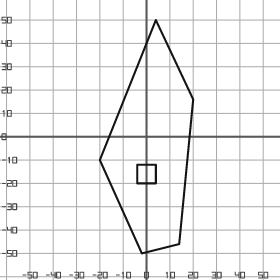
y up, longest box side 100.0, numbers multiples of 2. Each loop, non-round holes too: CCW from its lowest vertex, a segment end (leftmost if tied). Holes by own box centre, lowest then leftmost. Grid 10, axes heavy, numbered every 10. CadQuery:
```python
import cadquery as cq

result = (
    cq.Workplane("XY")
    .moveTo(-2.0, -50.0)
    .lineTo(14.0, -46.0)
    .lineTo(20.0, 16.0)
    .lineTo(4.0, 50.0)
    .lineTo(-20.0, -10.0)
    .close()
    .moveTo(-4.0, -20.0)
    .lineTo(4.0, -20.0)
    .lineTo(4.0, -12.0)
    .lineTo(-4.0, -12.0)
    .close()
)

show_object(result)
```